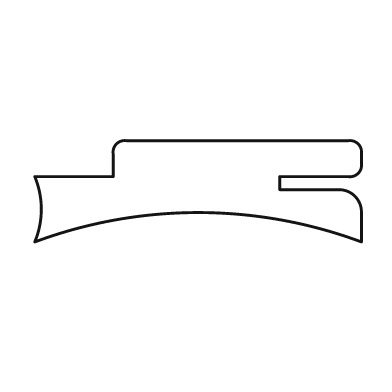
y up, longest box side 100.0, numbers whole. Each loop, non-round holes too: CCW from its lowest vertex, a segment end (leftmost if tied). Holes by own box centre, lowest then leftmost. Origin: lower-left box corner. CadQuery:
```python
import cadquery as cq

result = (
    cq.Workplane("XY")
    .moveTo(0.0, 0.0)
    .threePointArc((50.0, 9.0), (100.0, 0.0))
    .lineTo(100.0, 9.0)
    .threePointArc((98.0, 14.0), (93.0, 16.0))
    .lineTo(75.0, 16.0)
    .lineTo(75.0, 20.0)
    .lineTo(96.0, 20.0)
    .threePointArc((99.0, 21.0), (100.0, 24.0))
    .lineTo(100.0, 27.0)
    .threePointArc((99.0, 30.0), (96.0, 31.0))
    .lineTo(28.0, 31.0)
    .threePointArc((25.0, 30.0), (24.0, 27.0))
    .lineTo(24.0, 20.0)
    .lineTo(0.0, 20.0)
    .threePointArc((2.0, 10.0), (0.0, 0.0))
    .close()
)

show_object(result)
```